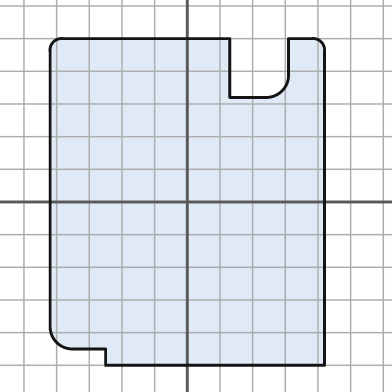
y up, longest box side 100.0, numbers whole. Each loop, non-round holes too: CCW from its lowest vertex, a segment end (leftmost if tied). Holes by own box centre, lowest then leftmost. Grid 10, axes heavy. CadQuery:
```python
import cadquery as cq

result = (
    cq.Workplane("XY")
    .moveTo(-25.0, -50.0)
    .lineTo(42.0, -50.0)
    .lineTo(42.0, 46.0)
    .threePointArc((41.0, 49.0), (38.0, 50.0))
    .lineTo(31.0, 50.0)
    .lineTo(31.0, 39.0)
    .threePointArc((29.0, 34.0), (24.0, 32.0))
    .lineTo(13.0, 32.0)
    .lineTo(13.0, 50.0)
    .lineTo(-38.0, 50.0)
    .threePointArc((-41.0, 49.0), (-42.0, 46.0))
    .lineTo(-42.0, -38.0)
    .threePointArc((-40.0, -43.0), (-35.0, -45.0))
    .lineTo(-25.0, -45.0)
    .close()
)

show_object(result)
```